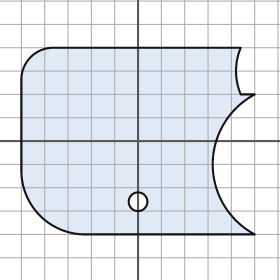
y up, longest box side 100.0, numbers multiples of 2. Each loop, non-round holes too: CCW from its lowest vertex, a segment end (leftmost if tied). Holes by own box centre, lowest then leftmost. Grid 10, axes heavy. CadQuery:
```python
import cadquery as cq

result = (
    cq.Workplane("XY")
    .moveTo(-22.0, -40.0)
    .lineTo(50.0, -40.0)
    .threePointArc((32.0, -10.0), (50.0, 20.0))
    .lineTo(44.0, 20.0)
    .threePointArc((42.0, 30.0), (44.0, 40.0))
    .lineTo(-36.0, 40.0)
    .threePointArc((-46.0, 36.0), (-50.0, 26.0))
    .lineTo(-50.0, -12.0)
    .threePointArc((-42.0, -32.0), (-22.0, -40.0))
    .close()
    .moveTo(0.0, -26.0)
    .circle(4.0)
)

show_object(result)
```